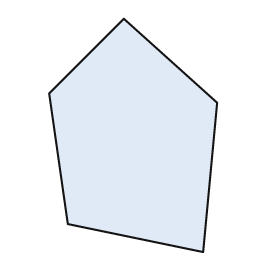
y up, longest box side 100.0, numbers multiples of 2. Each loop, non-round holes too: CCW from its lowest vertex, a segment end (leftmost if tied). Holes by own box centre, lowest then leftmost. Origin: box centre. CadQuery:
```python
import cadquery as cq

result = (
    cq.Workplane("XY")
    .moveTo(30.0, -50.0)
    .lineTo(36.0, 14.0)
    .lineTo(-4.0, 50.0)
    .lineTo(-36.0, 18.0)
    .lineTo(-28.0, -38.0)
    .close()
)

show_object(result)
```